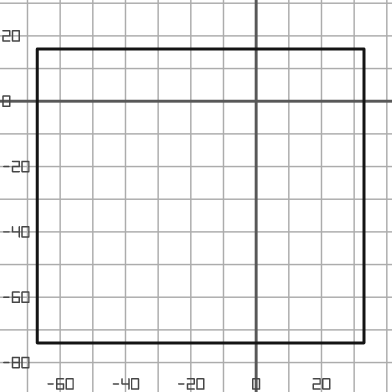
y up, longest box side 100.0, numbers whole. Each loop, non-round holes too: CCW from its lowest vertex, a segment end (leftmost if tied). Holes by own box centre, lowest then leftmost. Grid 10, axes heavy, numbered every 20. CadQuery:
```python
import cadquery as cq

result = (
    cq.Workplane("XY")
    .moveTo(-67.0, -74.0)
    .lineTo(33.0, -74.0)
    .lineTo(33.0, 16.0)
    .lineTo(-67.0, 16.0)
    .close()
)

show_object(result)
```